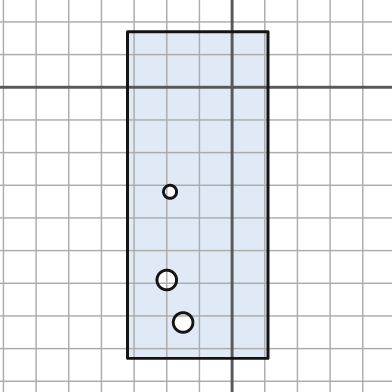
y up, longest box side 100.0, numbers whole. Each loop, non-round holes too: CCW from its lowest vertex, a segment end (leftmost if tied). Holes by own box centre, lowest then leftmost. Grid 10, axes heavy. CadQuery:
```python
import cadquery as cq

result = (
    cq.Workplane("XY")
    .moveTo(-32.0, -83.0)
    .lineTo(11.0, -83.0)
    .lineTo(11.0, 17.0)
    .lineTo(-32.0, 17.0)
    .close()
    .moveTo(-15.0, -72.0)
    .circle(3.0)
    .moveTo(-20.0, -59.0)
    .circle(3.0)
    .moveTo(-19.0, -32.0)
    .circle(2.0)
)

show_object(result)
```